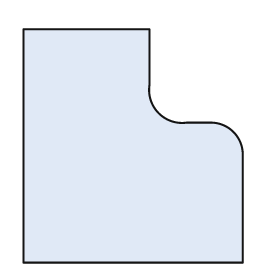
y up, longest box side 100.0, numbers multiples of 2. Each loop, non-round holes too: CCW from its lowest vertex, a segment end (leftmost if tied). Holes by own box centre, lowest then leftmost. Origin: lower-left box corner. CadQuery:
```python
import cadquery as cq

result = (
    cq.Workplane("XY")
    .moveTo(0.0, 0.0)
    .lineTo(94.0, 0.0)
    .lineTo(94.0, 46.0)
    .threePointArc((90.0, 56.0), (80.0, 60.0))
    .lineTo(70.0, 60.0)
    .threePointArc((58.0, 64.0), (54.0, 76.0))
    .lineTo(54.0, 100.0)
    .lineTo(0.0, 100.0)
    .close()
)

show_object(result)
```